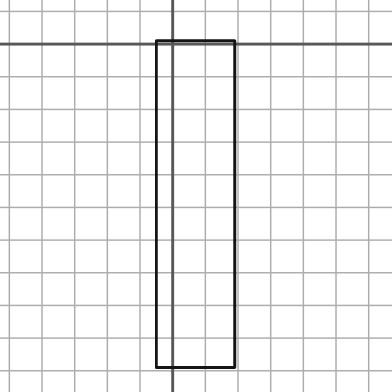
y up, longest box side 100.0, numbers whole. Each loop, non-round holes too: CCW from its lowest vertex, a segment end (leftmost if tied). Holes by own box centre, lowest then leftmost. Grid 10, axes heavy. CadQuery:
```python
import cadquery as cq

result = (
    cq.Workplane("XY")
    .moveTo(-5.0, -99.0)
    .lineTo(19.0, -99.0)
    .lineTo(19.0, 1.0)
    .lineTo(-5.0, 1.0)
    .close()
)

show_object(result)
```